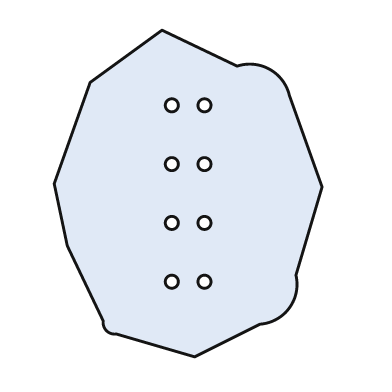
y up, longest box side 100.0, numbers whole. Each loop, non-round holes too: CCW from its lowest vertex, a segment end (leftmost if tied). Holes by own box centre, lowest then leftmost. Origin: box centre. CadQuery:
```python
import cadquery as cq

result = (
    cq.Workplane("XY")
    .moveTo(2.0, -50.0)
    .lineTo(22.0, -40.0)
    .threePointArc((31.0, -35.0), (33.0, -25.0))
    .lineTo(41.0, 2.0)
    .lineTo(31.0, 30.0)
    .threePointArc((25.0, 38.0), (15.0, 39.0))
    .lineTo(-8.0, 50.0)
    .lineTo(-30.0, 34.0)
    .lineTo(-41.0, 3.0)
    .lineTo(-37.0, -16.0)
    .lineTo(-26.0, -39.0)
    .threePointArc((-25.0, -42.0), (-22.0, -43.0))
    .close()
    .moveTo(-5.0, -27.0)
    .circle(2.0)
    .moveTo(5.0, -27.0)
    .circle(2.0)
    .moveTo(-5.0, -9.0)
    .circle(2.0)
    .moveTo(5.0, -9.0)
    .circle(2.0)
    .moveTo(-5.0, 9.0)
    .circle(2.0)
    .moveTo(5.0, 9.0)
    .circle(2.0)
    .moveTo(-5.0, 27.0)
    .circle(2.0)
    .moveTo(5.0, 27.0)
    .circle(2.0)
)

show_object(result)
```